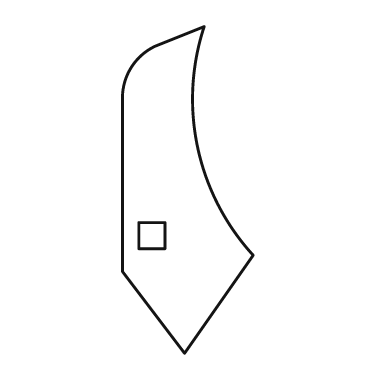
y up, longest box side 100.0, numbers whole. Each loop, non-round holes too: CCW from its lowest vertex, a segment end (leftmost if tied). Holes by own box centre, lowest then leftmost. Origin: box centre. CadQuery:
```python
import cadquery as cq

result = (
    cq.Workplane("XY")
    .moveTo(-1.0, -50.0)
    .lineTo(20.0, -20.0)
    .threePointArc((3.0, 13.0), (5.0, 50.0))
    .lineTo(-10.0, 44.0)
    .threePointArc((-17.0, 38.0), (-20.0, 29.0))
    .lineTo(-20.0, -25.0)
    .close()
    .moveTo(-15.0, -18.0)
    .lineTo(-7.0, -18.0)
    .lineTo(-7.0, -10.0)
    .lineTo(-15.0, -10.0)
    .close()
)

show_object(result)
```